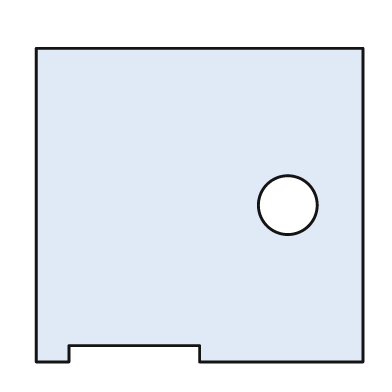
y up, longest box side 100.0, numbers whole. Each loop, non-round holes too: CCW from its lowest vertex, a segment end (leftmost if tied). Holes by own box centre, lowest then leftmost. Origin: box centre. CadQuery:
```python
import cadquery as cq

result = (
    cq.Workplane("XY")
    .moveTo(-50.0, -48.0)
    .lineTo(-40.0, -48.0)
    .lineTo(-40.0, -43.0)
    .lineTo(0.0, -43.0)
    .lineTo(0.0, -48.0)
    .lineTo(50.0, -48.0)
    .lineTo(50.0, 48.0)
    .lineTo(-50.0, 48.0)
    .close()
    .moveTo(27.0, 0.0)
    .circle(9.0)
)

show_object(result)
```